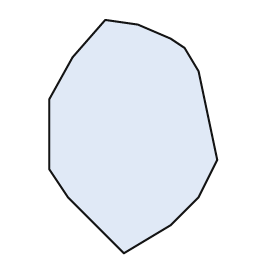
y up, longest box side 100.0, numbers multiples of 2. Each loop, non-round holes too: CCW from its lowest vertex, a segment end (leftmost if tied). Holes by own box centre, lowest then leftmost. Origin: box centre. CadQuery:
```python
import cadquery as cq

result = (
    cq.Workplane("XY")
    .moveTo(-4.0, -50.0)
    .lineTo(16.0, -38.0)
    .lineTo(28.0, -26.0)
    .lineTo(36.0, -10.0)
    .lineTo(28.0, 28.0)
    .lineTo(22.0, 38.0)
    .lineTo(16.0, 42.0)
    .lineTo(2.0, 48.0)
    .lineTo(-12.0, 50.0)
    .lineTo(-26.0, 34.0)
    .lineTo(-36.0, 16.0)
    .lineTo(-36.0, -14.0)
    .lineTo(-28.0, -26.0)
    .close()
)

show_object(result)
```